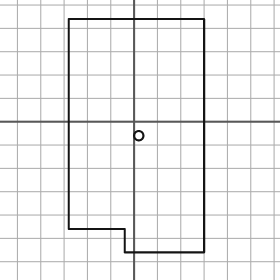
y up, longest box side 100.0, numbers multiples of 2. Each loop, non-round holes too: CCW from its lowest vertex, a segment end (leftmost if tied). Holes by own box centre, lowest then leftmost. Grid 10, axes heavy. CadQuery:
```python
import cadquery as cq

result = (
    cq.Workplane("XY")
    .moveTo(-4.0, -56.0)
    .lineTo(30.0, -56.0)
    .lineTo(30.0, 44.0)
    .lineTo(-28.0, 44.0)
    .lineTo(-28.0, -46.0)
    .lineTo(-4.0, -46.0)
    .close()
    .moveTo(2.0, -6.0)
    .circle(2.0)
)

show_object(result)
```